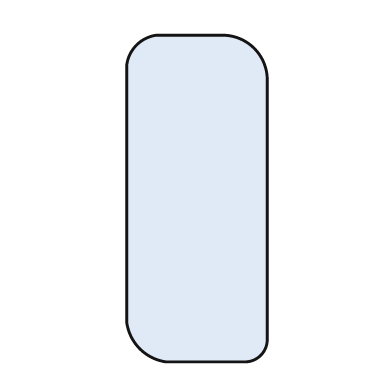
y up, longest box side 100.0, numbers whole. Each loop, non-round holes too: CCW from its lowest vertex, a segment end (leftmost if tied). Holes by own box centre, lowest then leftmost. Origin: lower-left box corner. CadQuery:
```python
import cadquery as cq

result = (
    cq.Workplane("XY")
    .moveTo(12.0, 0.0)
    .lineTo(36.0, 0.0)
    .threePointArc((41.0, 2.0), (43.0, 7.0))
    .lineTo(43.0, 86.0)
    .threePointArc((39.0, 96.0), (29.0, 100.0))
    .lineTo(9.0, 100.0)
    .threePointArc((3.0, 97.0), (0.0, 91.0))
    .lineTo(0.0, 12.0)
    .threePointArc((4.0, 4.0), (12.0, 0.0))
    .close()
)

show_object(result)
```